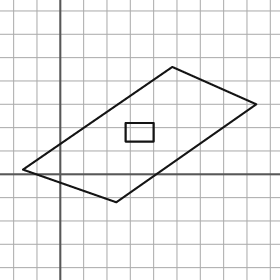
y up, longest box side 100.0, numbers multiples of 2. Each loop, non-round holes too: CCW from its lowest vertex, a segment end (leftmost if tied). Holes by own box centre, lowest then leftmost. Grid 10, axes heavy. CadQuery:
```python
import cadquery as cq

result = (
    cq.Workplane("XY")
    .moveTo(24.0, -12.0)
    .lineTo(84.0, 30.0)
    .lineTo(48.0, 46.0)
    .lineTo(-16.0, 2.0)
    .close()
    .moveTo(28.0, 14.0)
    .lineTo(40.0, 14.0)
    .lineTo(40.0, 22.0)
    .lineTo(28.0, 22.0)
    .close()
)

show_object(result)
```